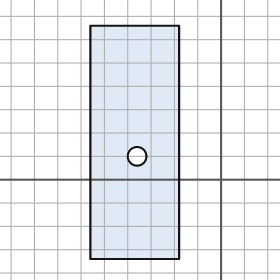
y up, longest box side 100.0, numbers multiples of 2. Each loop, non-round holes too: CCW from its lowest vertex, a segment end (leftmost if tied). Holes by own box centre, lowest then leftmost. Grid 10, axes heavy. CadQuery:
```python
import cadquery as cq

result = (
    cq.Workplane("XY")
    .moveTo(-56.0, -34.0)
    .lineTo(-18.0, -34.0)
    .lineTo(-18.0, 66.0)
    .lineTo(-56.0, 66.0)
    .close()
    .moveTo(-36.0, 10.0)
    .circle(4.0)
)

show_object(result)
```